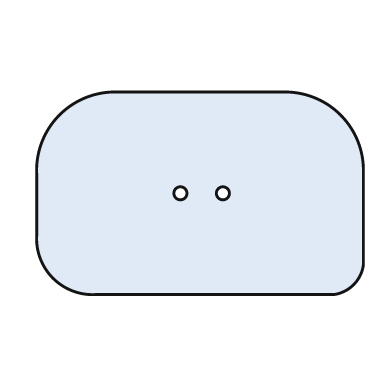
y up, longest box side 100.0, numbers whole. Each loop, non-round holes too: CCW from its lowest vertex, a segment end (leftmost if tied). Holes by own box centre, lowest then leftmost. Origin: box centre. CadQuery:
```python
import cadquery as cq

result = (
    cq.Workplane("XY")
    .moveTo(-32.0, -31.0)
    .lineTo(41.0, -31.0)
    .threePointArc((47.0, -28.0), (50.0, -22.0))
    .lineTo(50.0, 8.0)
    .threePointArc((43.0, 24.0), (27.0, 31.0))
    .lineTo(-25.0, 31.0)
    .threePointArc((-43.0, 24.0), (-50.0, 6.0))
    .lineTo(-50.0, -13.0)
    .threePointArc((-45.0, -26.0), (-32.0, -31.0))
    .close()
    .moveTo(-6.0, 0.0)
    .circle(2.0)
    .moveTo(7.0, 0.0)
    .circle(2.0)
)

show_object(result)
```